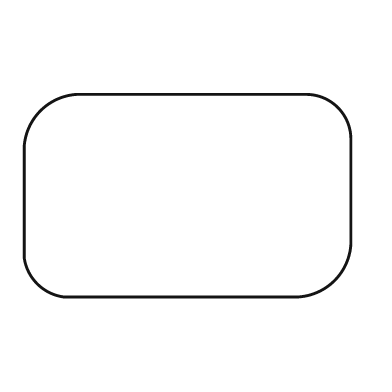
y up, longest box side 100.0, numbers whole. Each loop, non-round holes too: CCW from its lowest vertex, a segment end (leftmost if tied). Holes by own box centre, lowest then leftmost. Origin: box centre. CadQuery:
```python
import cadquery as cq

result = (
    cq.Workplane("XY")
    .moveTo(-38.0, -31.0)
    .lineTo(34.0, -31.0)
    .threePointArc((45.0, -26.0), (50.0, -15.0))
    .lineTo(50.0, 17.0)
    .threePointArc((46.0, 27.0), (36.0, 31.0))
    .lineTo(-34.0, 31.0)
    .threePointArc((-45.0, 26.0), (-50.0, 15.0))
    .lineTo(-50.0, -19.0)
    .threePointArc((-46.0, -27.0), (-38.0, -31.0))
    .close()
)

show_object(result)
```